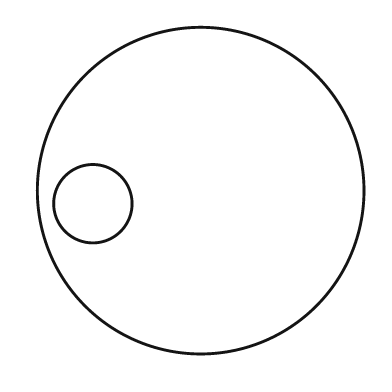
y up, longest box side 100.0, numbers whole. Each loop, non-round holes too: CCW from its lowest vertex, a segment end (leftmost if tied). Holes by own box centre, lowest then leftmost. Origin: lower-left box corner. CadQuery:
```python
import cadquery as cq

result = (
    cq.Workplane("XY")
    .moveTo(50.0, 50.0)
    .circle(50.0)
    .moveTo(17.0, 46.0)
    .circle(12.0)
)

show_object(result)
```